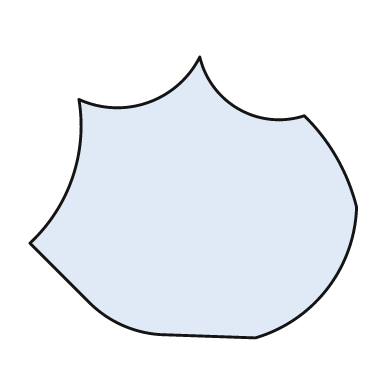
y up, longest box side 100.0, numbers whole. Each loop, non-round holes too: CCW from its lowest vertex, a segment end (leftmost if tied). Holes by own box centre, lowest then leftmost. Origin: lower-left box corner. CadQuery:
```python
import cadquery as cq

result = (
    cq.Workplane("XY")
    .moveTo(69.0, 0.0)
    .threePointArc((91.0, 15.0), (100.0, 40.0))
    .threePointArc((94.0, 55.0), (84.0, 68.0))
    .threePointArc((64.0, 70.0), (52.0, 86.0))
    .threePointArc((36.0, 72.0), (15.0, 73.0))
    .threePointArc((13.0, 49.0), (0.0, 29.0))
    .lineTo(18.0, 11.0)
    .threePointArc((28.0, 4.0), (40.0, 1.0))
    .close()
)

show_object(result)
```